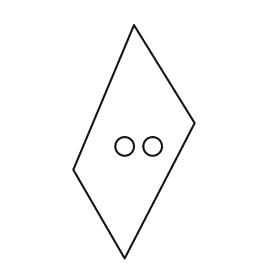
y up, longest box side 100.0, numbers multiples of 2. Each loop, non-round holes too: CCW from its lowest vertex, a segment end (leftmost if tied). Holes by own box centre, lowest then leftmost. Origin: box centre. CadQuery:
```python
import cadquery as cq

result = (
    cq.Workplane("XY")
    .moveTo(-4.0, -50.0)
    .lineTo(26.0, 8.0)
    .lineTo(0.0, 50.0)
    .lineTo(-26.0, -12.0)
    .close()
    .moveTo(-4.0, -2.0)
    .circle(4.0)
    .moveTo(8.0, -2.0)
    .circle(4.0)
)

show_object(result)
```